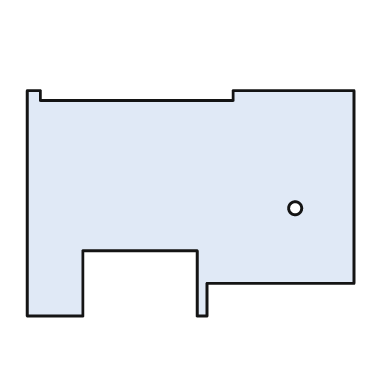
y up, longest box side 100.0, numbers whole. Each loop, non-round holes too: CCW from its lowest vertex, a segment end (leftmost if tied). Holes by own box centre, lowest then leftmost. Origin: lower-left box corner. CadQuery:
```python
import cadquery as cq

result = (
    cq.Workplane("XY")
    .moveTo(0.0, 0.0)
    .lineTo(17.0, 0.0)
    .lineTo(17.0, 20.0)
    .lineTo(52.0, 20.0)
    .lineTo(52.0, 0.0)
    .lineTo(55.0, 0.0)
    .lineTo(55.0, 10.0)
    .lineTo(100.0, 10.0)
    .lineTo(100.0, 69.0)
    .lineTo(63.0, 69.0)
    .lineTo(63.0, 66.0)
    .lineTo(4.0, 66.0)
    .lineTo(4.0, 69.0)
    .lineTo(0.0, 69.0)
    .close()
    .moveTo(82.0, 33.0)
    .circle(2.0)
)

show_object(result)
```